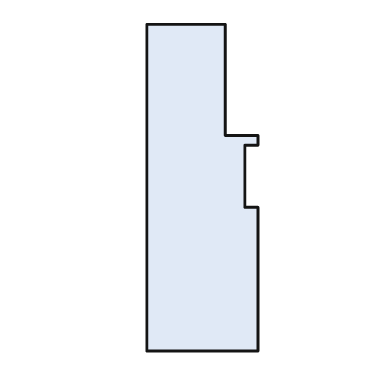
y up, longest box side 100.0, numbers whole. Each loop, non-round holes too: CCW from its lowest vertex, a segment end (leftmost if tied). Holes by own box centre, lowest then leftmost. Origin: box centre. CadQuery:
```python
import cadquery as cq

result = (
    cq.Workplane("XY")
    .moveTo(-17.0, -50.0)
    .lineTo(17.0, -50.0)
    .lineTo(17.0, -6.0)
    .lineTo(13.0, -6.0)
    .lineTo(13.0, 13.0)
    .lineTo(17.0, 13.0)
    .lineTo(17.0, 16.0)
    .lineTo(7.0, 16.0)
    .lineTo(7.0, 50.0)
    .lineTo(-17.0, 50.0)
    .close()
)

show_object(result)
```